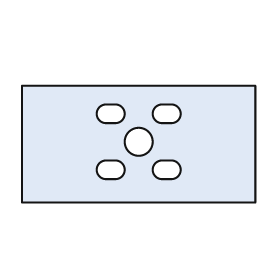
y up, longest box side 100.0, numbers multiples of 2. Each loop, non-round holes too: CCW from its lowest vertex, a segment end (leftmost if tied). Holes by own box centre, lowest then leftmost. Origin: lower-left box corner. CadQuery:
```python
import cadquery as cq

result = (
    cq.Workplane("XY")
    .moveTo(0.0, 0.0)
    .lineTo(100.0, 0.0)
    .lineTo(100.0, 50.0)
    .lineTo(0.0, 50.0)
    .close()
    .moveTo(36.0, 10.0)
    .lineTo(40.0, 10.0)
    .threePointArc((44.0, 14.0), (40.0, 18.0))
    .lineTo(36.0, 18.0)
    .threePointArc((32.0, 14.0), (36.0, 10.0))
    .close()
    .moveTo(60.0, 10.0)
    .lineTo(64.0, 10.0)
    .threePointArc((68.0, 14.0), (64.0, 18.0))
    .lineTo(60.0, 18.0)
    .threePointArc((56.0, 14.0), (60.0, 10.0))
    .close()
    .moveTo(50.0, 26.0)
    .circle(6.0)
    .moveTo(36.0, 34.0)
    .lineTo(40.0, 34.0)
    .threePointArc((44.0, 38.0), (40.0, 42.0))
    .lineTo(36.0, 42.0)
    .threePointArc((32.0, 38.0), (36.0, 34.0))
    .close()
    .moveTo(60.0, 34.0)
    .lineTo(64.0, 34.0)
    .threePointArc((68.0, 38.0), (64.0, 42.0))
    .lineTo(60.0, 42.0)
    .threePointArc((56.0, 38.0), (60.0, 34.0))
    .close()
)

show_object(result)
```